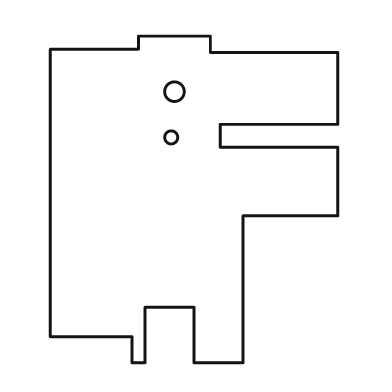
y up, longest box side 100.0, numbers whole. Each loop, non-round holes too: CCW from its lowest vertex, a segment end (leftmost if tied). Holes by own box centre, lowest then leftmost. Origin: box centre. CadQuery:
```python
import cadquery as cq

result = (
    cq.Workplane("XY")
    .moveTo(-19.0, -50.0)
    .lineTo(-15.0, -50.0)
    .lineTo(-15.0, -33.0)
    .lineTo(0.0, -33.0)
    .lineTo(0.0, -50.0)
    .lineTo(15.0, -50.0)
    .lineTo(15.0, -5.0)
    .lineTo(44.0, -5.0)
    .lineTo(44.0, 16.0)
    .lineTo(8.0, 16.0)
    .lineTo(8.0, 23.0)
    .lineTo(44.0, 23.0)
    .lineTo(44.0, 45.0)
    .lineTo(5.0, 45.0)
    .lineTo(5.0, 50.0)
    .lineTo(-17.0, 50.0)
    .lineTo(-17.0, 46.0)
    .lineTo(-44.0, 46.0)
    .lineTo(-44.0, -42.0)
    .lineTo(-19.0, -42.0)
    .close()
    .moveTo(-7.0, 19.0)
    .circle(2.0)
    .moveTo(-6.0, 33.0)
    .circle(3.0)
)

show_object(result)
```